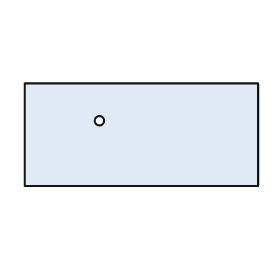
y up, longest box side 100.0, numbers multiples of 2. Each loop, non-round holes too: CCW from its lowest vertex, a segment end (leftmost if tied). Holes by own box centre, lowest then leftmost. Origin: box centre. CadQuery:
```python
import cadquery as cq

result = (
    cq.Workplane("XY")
    .moveTo(-50.0, -22.0)
    .lineTo(50.0, -22.0)
    .lineTo(50.0, 22.0)
    .lineTo(-50.0, 22.0)
    .close()
    .moveTo(-18.0, 6.0)
    .circle(2.0)
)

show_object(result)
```